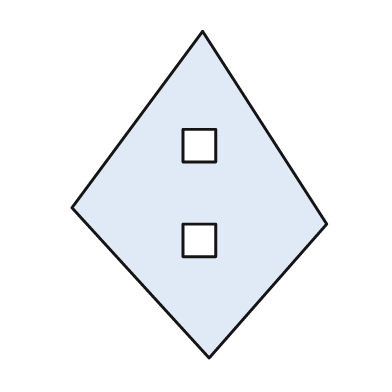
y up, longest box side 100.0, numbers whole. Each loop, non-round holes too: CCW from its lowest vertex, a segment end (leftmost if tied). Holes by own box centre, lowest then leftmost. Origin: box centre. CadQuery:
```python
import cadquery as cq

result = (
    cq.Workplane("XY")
    .moveTo(3.0, -50.0)
    .lineTo(39.0, -9.0)
    .lineTo(1.0, 50.0)
    .lineTo(-39.0, -4.0)
    .close()
    .moveTo(-5.0, -19.0)
    .lineTo(5.0, -19.0)
    .lineTo(5.0, -9.0)
    .lineTo(-5.0, -9.0)
    .close()
    .moveTo(-5.0, 10.0)
    .lineTo(5.0, 10.0)
    .lineTo(5.0, 20.0)
    .lineTo(-5.0, 20.0)
    .close()
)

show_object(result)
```